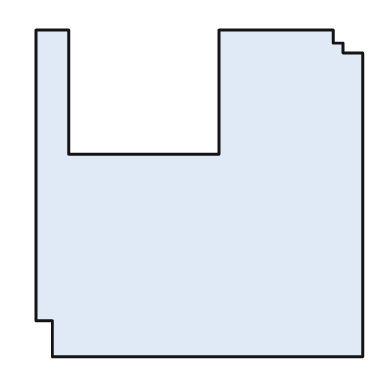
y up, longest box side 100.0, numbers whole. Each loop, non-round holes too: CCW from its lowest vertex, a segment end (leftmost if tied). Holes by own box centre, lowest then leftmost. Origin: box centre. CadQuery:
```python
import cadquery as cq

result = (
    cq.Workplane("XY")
    .moveTo(-45.0, -50.0)
    .lineTo(50.0, -50.0)
    .lineTo(50.0, 43.0)
    .lineTo(44.0, 43.0)
    .lineTo(44.0, 46.0)
    .lineTo(41.0, 46.0)
    .lineTo(41.0, 50.0)
    .lineTo(6.0, 50.0)
    .lineTo(6.0, 12.0)
    .lineTo(-40.0, 12.0)
    .lineTo(-40.0, 50.0)
    .lineTo(-50.0, 50.0)
    .lineTo(-50.0, -39.0)
    .lineTo(-45.0, -39.0)
    .close()
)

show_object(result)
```